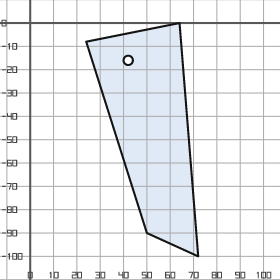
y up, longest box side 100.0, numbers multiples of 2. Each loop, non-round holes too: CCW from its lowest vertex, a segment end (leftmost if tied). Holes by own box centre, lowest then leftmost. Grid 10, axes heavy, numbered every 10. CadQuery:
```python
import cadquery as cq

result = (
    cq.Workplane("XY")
    .moveTo(72.0, -100.0)
    .lineTo(64.0, 0.0)
    .lineTo(24.0, -8.0)
    .lineTo(50.0, -90.0)
    .close()
    .moveTo(42.0, -16.0)
    .circle(2.0)
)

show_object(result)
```